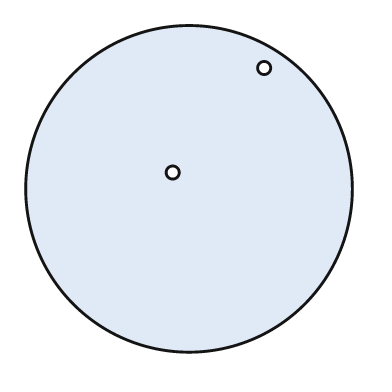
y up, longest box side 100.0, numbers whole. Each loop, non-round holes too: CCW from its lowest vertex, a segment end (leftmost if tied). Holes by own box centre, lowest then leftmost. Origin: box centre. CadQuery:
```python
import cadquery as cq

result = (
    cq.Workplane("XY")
    .moveTo(0.0, 0.0)
    .circle(50.0)
    .moveTo(-5.0, 5.0)
    .circle(2.0)
    .moveTo(23.0, 37.0)
    .circle(2.0)
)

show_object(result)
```